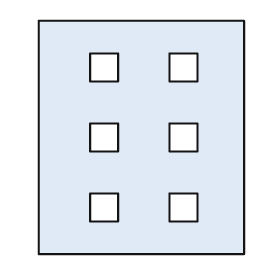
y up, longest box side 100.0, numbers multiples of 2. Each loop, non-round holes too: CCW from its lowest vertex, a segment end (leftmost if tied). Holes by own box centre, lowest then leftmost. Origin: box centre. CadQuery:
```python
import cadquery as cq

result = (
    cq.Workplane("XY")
    .moveTo(-44.0, -50.0)
    .lineTo(44.0, -50.0)
    .lineTo(44.0, 50.0)
    .lineTo(-44.0, 50.0)
    .close()
    .moveTo(-22.0, -36.0)
    .lineTo(-10.0, -36.0)
    .lineTo(-10.0, -24.0)
    .lineTo(-22.0, -24.0)
    .close()
    .moveTo(12.0, -36.0)
    .lineTo(24.0, -36.0)
    .lineTo(24.0, -24.0)
    .lineTo(12.0, -24.0)
    .close()
    .moveTo(-22.0, -6.0)
    .lineTo(-10.0, -6.0)
    .lineTo(-10.0, 6.0)
    .lineTo(-22.0, 6.0)
    .close()
    .moveTo(12.0, -6.0)
    .lineTo(24.0, -6.0)
    .lineTo(24.0, 6.0)
    .lineTo(12.0, 6.0)
    .close()
    .moveTo(-22.0, 24.0)
    .lineTo(-10.0, 24.0)
    .lineTo(-10.0, 36.0)
    .lineTo(-22.0, 36.0)
    .close()
    .moveTo(12.0, 24.0)
    .lineTo(24.0, 24.0)
    .lineTo(24.0, 36.0)
    .lineTo(12.0, 36.0)
    .close()
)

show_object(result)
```